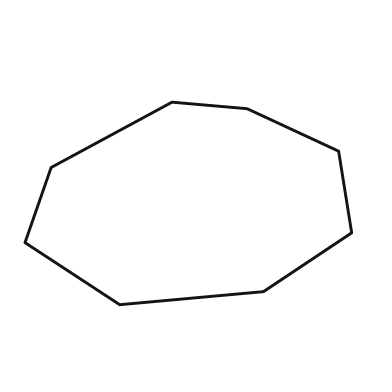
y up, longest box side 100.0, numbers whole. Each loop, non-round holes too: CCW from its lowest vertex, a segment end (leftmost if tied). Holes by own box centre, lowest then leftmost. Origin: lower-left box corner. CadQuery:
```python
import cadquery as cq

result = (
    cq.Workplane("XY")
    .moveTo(29.0, 0.0)
    .lineTo(73.0, 4.0)
    .lineTo(100.0, 22.0)
    .lineTo(96.0, 47.0)
    .lineTo(68.0, 60.0)
    .lineTo(45.0, 62.0)
    .lineTo(8.0, 42.0)
    .lineTo(0.0, 19.0)
    .close()
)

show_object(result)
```